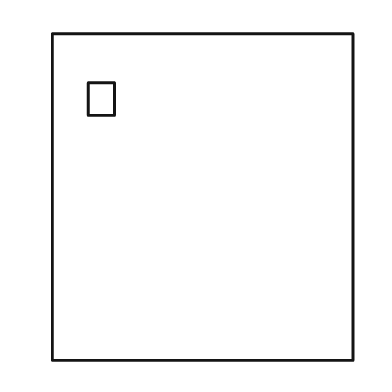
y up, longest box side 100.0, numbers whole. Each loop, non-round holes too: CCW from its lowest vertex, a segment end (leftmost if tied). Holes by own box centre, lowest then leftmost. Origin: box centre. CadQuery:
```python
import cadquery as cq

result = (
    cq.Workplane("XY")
    .moveTo(-46.0, -50.0)
    .lineTo(46.0, -50.0)
    .lineTo(46.0, 50.0)
    .lineTo(-46.0, 50.0)
    .close()
    .moveTo(-35.0, 25.0)
    .lineTo(-27.0, 25.0)
    .lineTo(-27.0, 35.0)
    .lineTo(-35.0, 35.0)
    .close()
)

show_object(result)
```